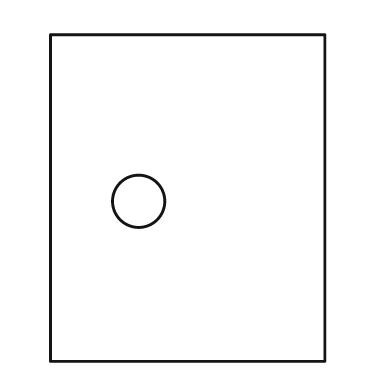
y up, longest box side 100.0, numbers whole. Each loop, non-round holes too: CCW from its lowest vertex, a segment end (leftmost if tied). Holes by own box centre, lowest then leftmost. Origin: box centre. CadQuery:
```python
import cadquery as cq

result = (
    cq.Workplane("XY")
    .moveTo(-42.0, -50.0)
    .lineTo(42.0, -50.0)
    .lineTo(42.0, 50.0)
    .lineTo(-42.0, 50.0)
    .close()
    .moveTo(-15.0, -1.0)
    .circle(8.0)
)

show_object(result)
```